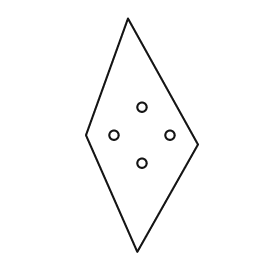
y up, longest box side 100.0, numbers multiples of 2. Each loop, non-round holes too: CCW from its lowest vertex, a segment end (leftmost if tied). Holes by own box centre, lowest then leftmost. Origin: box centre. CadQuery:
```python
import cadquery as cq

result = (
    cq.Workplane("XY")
    .moveTo(-2.0, -50.0)
    .lineTo(24.0, -4.0)
    .lineTo(-6.0, 50.0)
    .lineTo(-24.0, 0.0)
    .close()
    .moveTo(0.0, -12.0)
    .circle(2.0)
    .moveTo(-12.0, 0.0)
    .circle(2.0)
    .moveTo(12.0, 0.0)
    .circle(2.0)
    .moveTo(0.0, 12.0)
    .circle(2.0)
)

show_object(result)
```